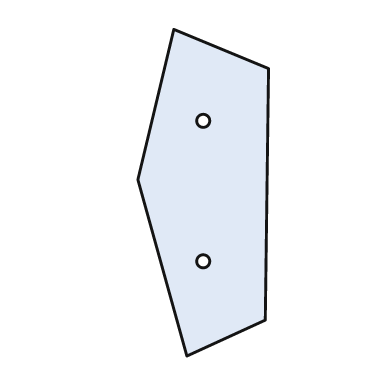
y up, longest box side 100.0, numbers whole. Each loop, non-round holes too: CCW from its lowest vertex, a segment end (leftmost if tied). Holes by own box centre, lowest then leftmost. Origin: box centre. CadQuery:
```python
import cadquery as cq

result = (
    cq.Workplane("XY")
    .moveTo(-5.0, -50.0)
    .lineTo(19.0, -39.0)
    .lineTo(20.0, 38.0)
    .lineTo(-9.0, 50.0)
    .lineTo(-20.0, 4.0)
    .close()
    .moveTo(0.0, -21.0)
    .circle(2.0)
    .moveTo(0.0, 22.0)
    .circle(2.0)
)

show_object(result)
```